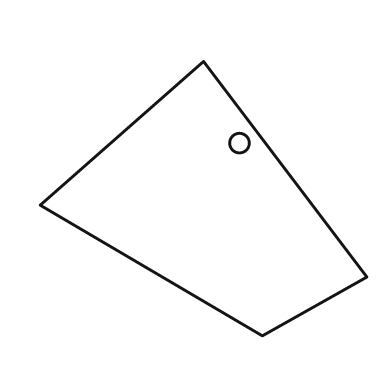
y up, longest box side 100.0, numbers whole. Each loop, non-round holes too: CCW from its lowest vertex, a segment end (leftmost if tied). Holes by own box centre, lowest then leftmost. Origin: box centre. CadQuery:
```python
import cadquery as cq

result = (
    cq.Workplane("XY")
    .moveTo(18.0, -42.0)
    .lineTo(50.0, -24.0)
    .lineTo(0.0, 42.0)
    .lineTo(-50.0, -2.0)
    .close()
    .moveTo(11.0, 17.0)
    .circle(3.0)
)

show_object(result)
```